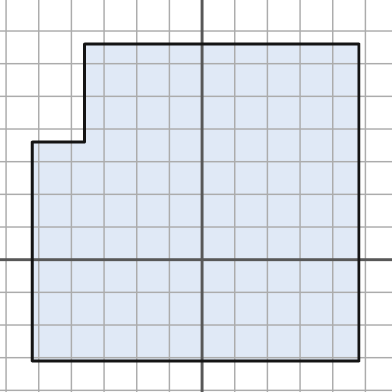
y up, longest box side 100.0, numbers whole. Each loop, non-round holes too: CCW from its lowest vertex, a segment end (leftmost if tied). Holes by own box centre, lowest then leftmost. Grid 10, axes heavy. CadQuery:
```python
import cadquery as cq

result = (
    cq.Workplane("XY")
    .moveTo(-52.0, -31.0)
    .lineTo(48.0, -31.0)
    .lineTo(48.0, 66.0)
    .lineTo(-36.0, 66.0)
    .lineTo(-36.0, 36.0)
    .lineTo(-52.0, 36.0)
    .close()
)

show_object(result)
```